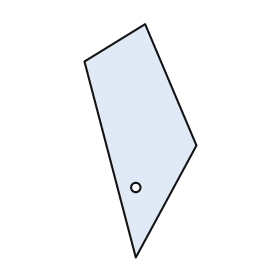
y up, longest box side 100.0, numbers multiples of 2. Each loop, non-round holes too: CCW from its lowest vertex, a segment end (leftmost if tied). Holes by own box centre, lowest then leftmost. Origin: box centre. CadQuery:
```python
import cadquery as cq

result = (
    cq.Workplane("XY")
    .moveTo(-2.0, -50.0)
    .lineTo(24.0, -2.0)
    .lineTo(2.0, 50.0)
    .lineTo(-24.0, 34.0)
    .close()
    .moveTo(-2.0, -20.0)
    .circle(2.0)
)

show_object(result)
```